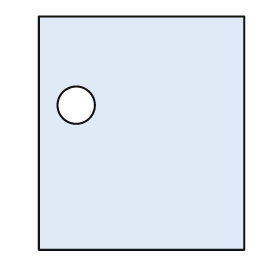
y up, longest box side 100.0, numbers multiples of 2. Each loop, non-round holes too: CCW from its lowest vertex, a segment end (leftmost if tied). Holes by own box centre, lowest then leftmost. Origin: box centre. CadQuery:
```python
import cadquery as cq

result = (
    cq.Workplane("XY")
    .moveTo(-44.0, -50.0)
    .lineTo(44.0, -50.0)
    .lineTo(44.0, 50.0)
    .lineTo(-44.0, 50.0)
    .close()
    .moveTo(-28.0, 12.0)
    .circle(8.0)
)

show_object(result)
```